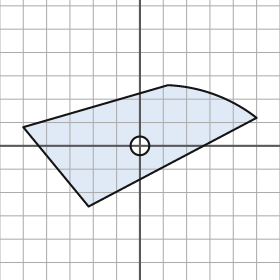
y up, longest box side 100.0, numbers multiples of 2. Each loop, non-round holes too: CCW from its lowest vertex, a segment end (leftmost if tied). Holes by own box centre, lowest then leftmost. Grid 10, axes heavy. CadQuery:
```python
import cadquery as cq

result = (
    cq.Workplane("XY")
    .moveTo(-22.0, -26.0)
    .lineTo(50.0, 12.0)
    .threePointArc((32.0, 22.0), (12.0, 26.0))
    .lineTo(-50.0, 8.0)
    .close()
    .moveTo(0.0, 0.0)
    .circle(4.0)
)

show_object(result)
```